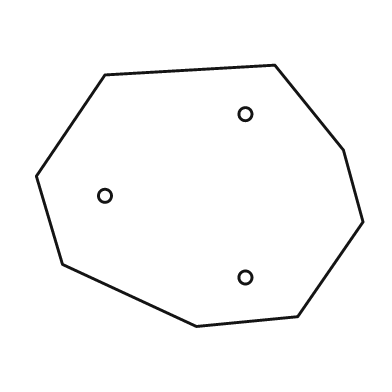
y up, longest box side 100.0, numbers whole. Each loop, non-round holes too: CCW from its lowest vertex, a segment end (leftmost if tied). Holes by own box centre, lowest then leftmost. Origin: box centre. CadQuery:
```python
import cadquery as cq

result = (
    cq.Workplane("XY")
    .moveTo(-1.0, -40.0)
    .lineTo(30.0, -37.0)
    .lineTo(50.0, -8.0)
    .lineTo(44.0, 14.0)
    .lineTo(23.0, 40.0)
    .lineTo(-29.0, 37.0)
    .lineTo(-50.0, 6.0)
    .lineTo(-42.0, -21.0)
    .close()
    .moveTo(14.0, -25.0)
    .circle(2.0)
    .moveTo(-29.0, 0.0)
    .circle(2.0)
    .moveTo(14.0, 25.0)
    .circle(2.0)
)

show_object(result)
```